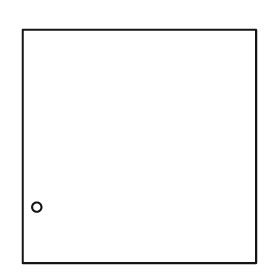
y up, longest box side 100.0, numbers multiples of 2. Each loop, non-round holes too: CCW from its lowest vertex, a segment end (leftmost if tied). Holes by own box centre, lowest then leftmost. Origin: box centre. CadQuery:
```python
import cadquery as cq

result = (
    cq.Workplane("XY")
    .moveTo(-50.0, -50.0)
    .lineTo(50.0, -50.0)
    .lineTo(50.0, 50.0)
    .lineTo(-50.0, 50.0)
    .close()
    .moveTo(-44.0, -26.0)
    .circle(2.0)
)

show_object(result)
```